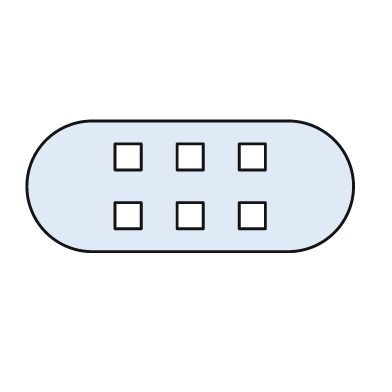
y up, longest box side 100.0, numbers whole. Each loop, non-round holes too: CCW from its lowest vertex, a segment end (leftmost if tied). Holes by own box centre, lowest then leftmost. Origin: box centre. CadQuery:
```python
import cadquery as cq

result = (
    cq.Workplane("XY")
    .moveTo(-30.0, -20.0)
    .lineTo(30.0, -20.0)
    .threePointArc((50.0, 0.0), (30.0, 20.0))
    .lineTo(-30.0, 20.0)
    .threePointArc((-50.0, 0.0), (-30.0, -20.0))
    .close()
    .moveTo(-23.0, -13.0)
    .lineTo(-15.0, -13.0)
    .lineTo(-15.0, -5.0)
    .lineTo(-23.0, -5.0)
    .close()
    .moveTo(-4.0, -13.0)
    .lineTo(4.0, -13.0)
    .lineTo(4.0, -5.0)
    .lineTo(-4.0, -5.0)
    .close()
    .moveTo(15.0, -13.0)
    .lineTo(23.0, -13.0)
    .lineTo(23.0, -5.0)
    .lineTo(15.0, -5.0)
    .close()
    .moveTo(-23.0, 5.0)
    .lineTo(-15.0, 5.0)
    .lineTo(-15.0, 13.0)
    .lineTo(-23.0, 13.0)
    .close()
    .moveTo(-4.0, 5.0)
    .lineTo(4.0, 5.0)
    .lineTo(4.0, 13.0)
    .lineTo(-4.0, 13.0)
    .close()
    .moveTo(15.0, 5.0)
    .lineTo(23.0, 5.0)
    .lineTo(23.0, 13.0)
    .lineTo(15.0, 13.0)
    .close()
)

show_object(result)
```